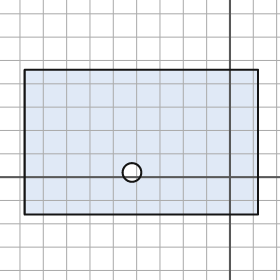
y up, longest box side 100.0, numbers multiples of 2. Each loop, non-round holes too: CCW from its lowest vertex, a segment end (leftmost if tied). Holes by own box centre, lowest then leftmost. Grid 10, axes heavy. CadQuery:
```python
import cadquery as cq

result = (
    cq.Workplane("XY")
    .moveTo(-88.0, -16.0)
    .lineTo(12.0, -16.0)
    .lineTo(12.0, 46.0)
    .lineTo(-88.0, 46.0)
    .close()
    .moveTo(-42.0, 2.0)
    .circle(4.0)
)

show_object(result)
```